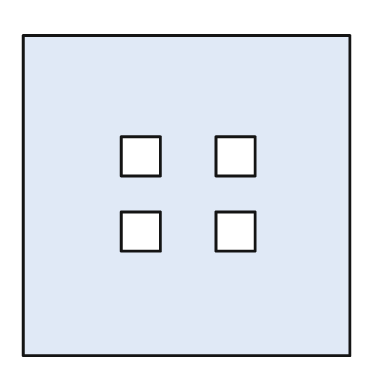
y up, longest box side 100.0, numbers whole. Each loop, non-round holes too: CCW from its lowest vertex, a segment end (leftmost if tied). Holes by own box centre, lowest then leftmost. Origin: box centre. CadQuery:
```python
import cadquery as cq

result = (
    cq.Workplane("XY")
    .moveTo(-50.0, -49.0)
    .lineTo(50.0, -49.0)
    .lineTo(50.0, 49.0)
    .lineTo(-50.0, 49.0)
    .close()
    .moveTo(-20.0, -17.0)
    .lineTo(-8.0, -17.0)
    .lineTo(-8.0, -5.0)
    .lineTo(-20.0, -5.0)
    .close()
    .moveTo(9.0, -17.0)
    .lineTo(21.0, -17.0)
    .lineTo(21.0, -5.0)
    .lineTo(9.0, -5.0)
    .close()
    .moveTo(-20.0, 6.0)
    .lineTo(-8.0, 6.0)
    .lineTo(-8.0, 18.0)
    .lineTo(-20.0, 18.0)
    .close()
    .moveTo(9.0, 6.0)
    .lineTo(21.0, 6.0)
    .lineTo(21.0, 18.0)
    .lineTo(9.0, 18.0)
    .close()
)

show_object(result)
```